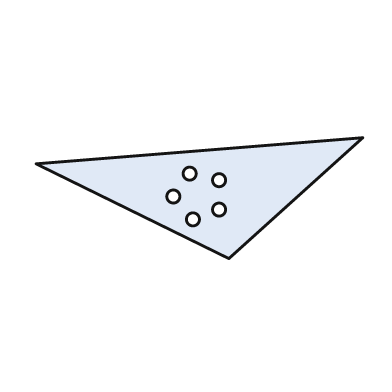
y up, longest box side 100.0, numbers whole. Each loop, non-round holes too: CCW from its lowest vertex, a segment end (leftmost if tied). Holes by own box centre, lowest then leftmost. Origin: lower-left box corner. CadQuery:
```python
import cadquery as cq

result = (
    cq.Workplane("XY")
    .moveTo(59.0, 0.0)
    .lineTo(100.0, 37.0)
    .lineTo(0.0, 29.0)
    .close()
    .moveTo(48.0, 12.0)
    .circle(2.0)
    .moveTo(56.0, 15.0)
    .circle(2.0)
    .moveTo(42.0, 19.0)
    .circle(2.0)
    .moveTo(56.0, 24.0)
    .circle(2.0)
    .moveTo(47.0, 26.0)
    .circle(2.0)
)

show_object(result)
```